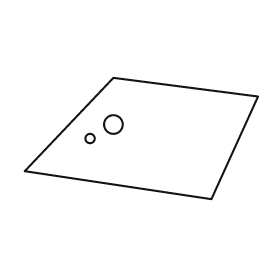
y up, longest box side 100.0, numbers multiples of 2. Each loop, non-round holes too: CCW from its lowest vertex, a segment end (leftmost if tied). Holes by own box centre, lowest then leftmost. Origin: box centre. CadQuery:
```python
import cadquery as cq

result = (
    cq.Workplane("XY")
    .moveTo(30.0, -26.0)
    .lineTo(50.0, 18.0)
    .lineTo(-12.0, 26.0)
    .lineTo(-50.0, -14.0)
    .close()
    .moveTo(-22.0, 0.0)
    .circle(2.0)
    .moveTo(-12.0, 6.0)
    .circle(4.0)
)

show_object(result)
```